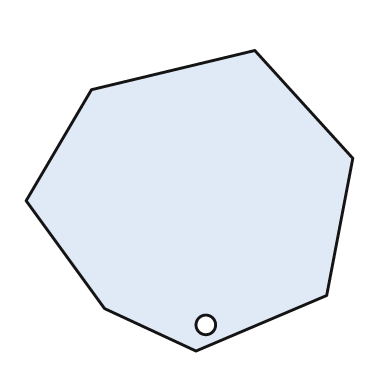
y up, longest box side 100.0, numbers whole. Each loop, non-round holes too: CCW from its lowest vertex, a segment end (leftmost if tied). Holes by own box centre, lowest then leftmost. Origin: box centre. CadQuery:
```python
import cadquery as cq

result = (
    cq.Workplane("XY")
    .moveTo(2.0, -46.0)
    .lineTo(42.0, -29.0)
    .lineTo(50.0, 13.0)
    .lineTo(20.0, 46.0)
    .lineTo(-30.0, 34.0)
    .lineTo(-50.0, 0.0)
    .lineTo(-26.0, -33.0)
    .close()
    .moveTo(5.0, -38.0)
    .circle(3.0)
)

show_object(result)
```